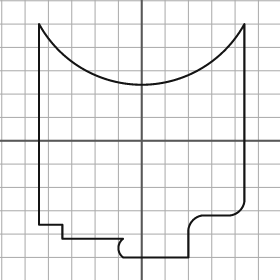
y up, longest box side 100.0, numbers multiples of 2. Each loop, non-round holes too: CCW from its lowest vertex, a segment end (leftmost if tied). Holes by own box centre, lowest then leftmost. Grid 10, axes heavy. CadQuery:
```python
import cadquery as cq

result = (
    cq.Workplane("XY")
    .moveTo(-8.0, -50.0)
    .lineTo(20.0, -50.0)
    .lineTo(20.0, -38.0)
    .threePointArc((22.0, -34.0), (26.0, -32.0))
    .lineTo(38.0, -32.0)
    .threePointArc((42.0, -30.0), (44.0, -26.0))
    .lineTo(44.0, 50.0)
    .threePointArc((0.0, 24.0), (-44.0, 50.0))
    .lineTo(-44.0, -36.0)
    .lineTo(-34.0, -36.0)
    .lineTo(-34.0, -42.0)
    .lineTo(-8.0, -42.0)
    .threePointArc((-10.0, -46.0), (-8.0, -50.0))
    .close()
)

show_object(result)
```